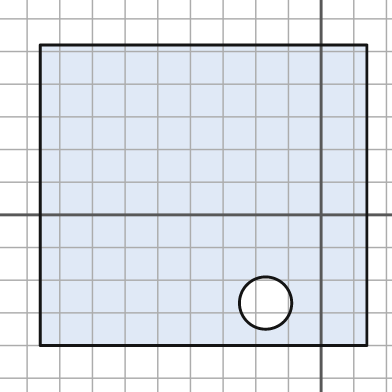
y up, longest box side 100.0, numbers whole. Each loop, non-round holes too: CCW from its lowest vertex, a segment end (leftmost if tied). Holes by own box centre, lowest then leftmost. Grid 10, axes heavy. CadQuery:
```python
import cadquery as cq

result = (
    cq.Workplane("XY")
    .moveTo(-86.0, -40.0)
    .lineTo(14.0, -40.0)
    .lineTo(14.0, 52.0)
    .lineTo(-86.0, 52.0)
    .close()
    .moveTo(-17.0, -27.0)
    .circle(8.0)
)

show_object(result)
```